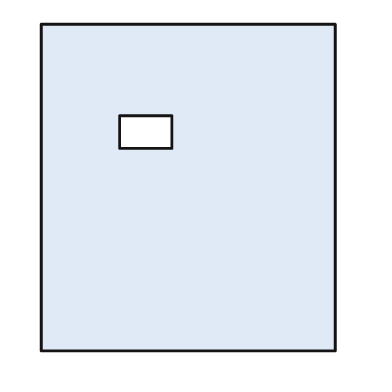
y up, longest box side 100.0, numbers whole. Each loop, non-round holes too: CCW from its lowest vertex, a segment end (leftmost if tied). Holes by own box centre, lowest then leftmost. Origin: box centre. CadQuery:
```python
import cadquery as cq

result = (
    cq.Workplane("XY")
    .moveTo(-45.0, -50.0)
    .lineTo(45.0, -50.0)
    .lineTo(45.0, 50.0)
    .lineTo(-45.0, 50.0)
    .close()
    .moveTo(-21.0, 12.0)
    .lineTo(-5.0, 12.0)
    .lineTo(-5.0, 22.0)
    .lineTo(-21.0, 22.0)
    .close()
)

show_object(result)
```